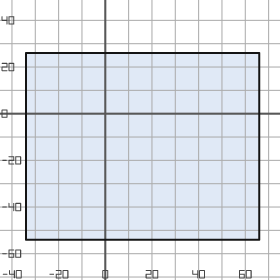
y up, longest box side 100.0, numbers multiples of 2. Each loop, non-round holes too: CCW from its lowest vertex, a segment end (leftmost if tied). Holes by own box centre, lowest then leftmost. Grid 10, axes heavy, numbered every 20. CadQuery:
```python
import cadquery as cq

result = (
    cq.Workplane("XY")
    .moveTo(-34.0, -54.0)
    .lineTo(66.0, -54.0)
    .lineTo(66.0, 26.0)
    .lineTo(-34.0, 26.0)
    .close()
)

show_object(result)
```